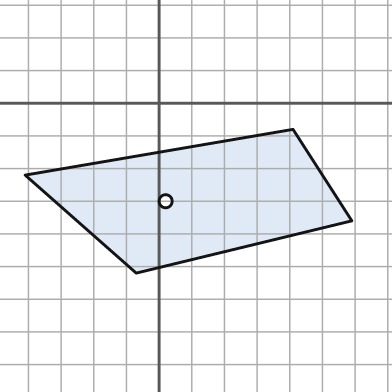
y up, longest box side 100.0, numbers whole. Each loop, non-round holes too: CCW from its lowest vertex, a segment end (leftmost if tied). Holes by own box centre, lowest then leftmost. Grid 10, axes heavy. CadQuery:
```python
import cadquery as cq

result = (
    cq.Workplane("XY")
    .moveTo(-7.0, -52.0)
    .lineTo(59.0, -36.0)
    .lineTo(41.0, -8.0)
    .lineTo(-41.0, -22.0)
    .close()
    .moveTo(2.0, -30.0)
    .circle(2.0)
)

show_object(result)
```